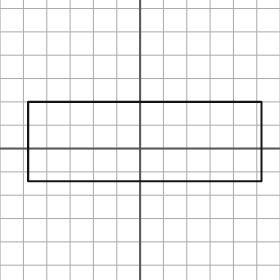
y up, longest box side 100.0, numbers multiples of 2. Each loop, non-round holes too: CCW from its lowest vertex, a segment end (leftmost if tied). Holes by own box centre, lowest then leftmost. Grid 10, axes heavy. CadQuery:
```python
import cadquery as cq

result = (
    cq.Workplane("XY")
    .moveTo(-48.0, -14.0)
    .lineTo(52.0, -14.0)
    .lineTo(52.0, 20.0)
    .lineTo(-48.0, 20.0)
    .close()
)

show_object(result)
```